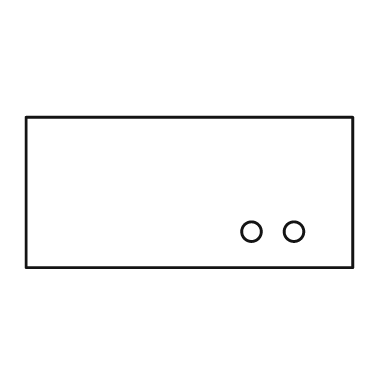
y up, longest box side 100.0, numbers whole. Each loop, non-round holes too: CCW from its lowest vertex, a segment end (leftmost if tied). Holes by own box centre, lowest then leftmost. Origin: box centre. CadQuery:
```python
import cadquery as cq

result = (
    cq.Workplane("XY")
    .moveTo(-50.0, -23.0)
    .lineTo(50.0, -23.0)
    .lineTo(50.0, 23.0)
    .lineTo(-50.0, 23.0)
    .close()
    .moveTo(19.0, -12.0)
    .circle(3.0)
    .moveTo(32.0, -12.0)
    .circle(3.0)
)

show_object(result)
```